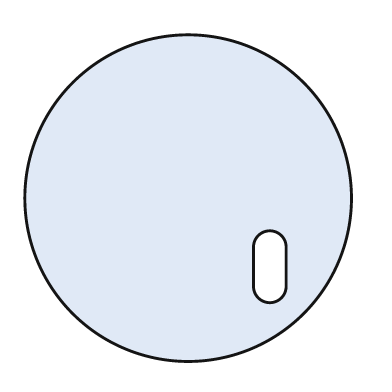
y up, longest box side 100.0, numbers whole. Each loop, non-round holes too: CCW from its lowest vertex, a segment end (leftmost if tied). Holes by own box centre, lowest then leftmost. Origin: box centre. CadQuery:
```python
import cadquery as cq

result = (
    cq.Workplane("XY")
    .moveTo(0.0, 0.0)
    .circle(50.0)
    .moveTo(20.0, -27.0)
    .threePointArc((25.0, -32.0), (30.0, -27.0))
    .lineTo(30.0, -15.0)
    .threePointArc((25.0, -10.0), (20.0, -15.0))
    .close()
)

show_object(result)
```